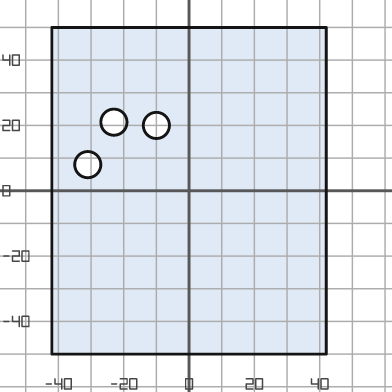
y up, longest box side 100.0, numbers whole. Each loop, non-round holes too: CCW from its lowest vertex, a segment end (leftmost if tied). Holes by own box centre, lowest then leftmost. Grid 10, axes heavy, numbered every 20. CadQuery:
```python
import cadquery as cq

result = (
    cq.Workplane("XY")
    .moveTo(-42.0, -50.0)
    .lineTo(42.0, -50.0)
    .lineTo(42.0, 50.0)
    .lineTo(-42.0, 50.0)
    .close()
    .moveTo(-31.0, 8.0)
    .circle(4.0)
    .moveTo(-10.0, 20.0)
    .circle(4.0)
    .moveTo(-23.0, 21.0)
    .circle(4.0)
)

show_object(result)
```